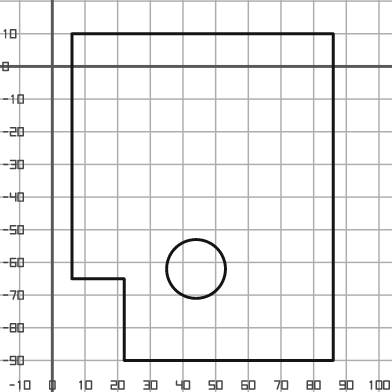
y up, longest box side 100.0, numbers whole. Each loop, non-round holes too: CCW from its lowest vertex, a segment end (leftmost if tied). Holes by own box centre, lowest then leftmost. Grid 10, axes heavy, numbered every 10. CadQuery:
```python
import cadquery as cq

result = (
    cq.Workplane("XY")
    .moveTo(22.0, -90.0)
    .lineTo(86.0, -90.0)
    .lineTo(86.0, 10.0)
    .lineTo(6.0, 10.0)
    .lineTo(6.0, -65.0)
    .lineTo(22.0, -65.0)
    .close()
    .moveTo(44.0, -62.0)
    .circle(9.0)
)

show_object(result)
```